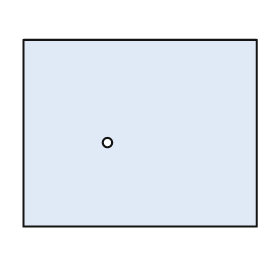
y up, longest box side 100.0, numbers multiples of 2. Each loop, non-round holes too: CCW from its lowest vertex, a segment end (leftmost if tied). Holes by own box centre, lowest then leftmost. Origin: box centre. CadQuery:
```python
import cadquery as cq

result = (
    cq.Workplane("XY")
    .moveTo(-50.0, -40.0)
    .lineTo(50.0, -40.0)
    .lineTo(50.0, 40.0)
    .lineTo(-50.0, 40.0)
    .close()
    .moveTo(-14.0, -4.0)
    .circle(2.0)
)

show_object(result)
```